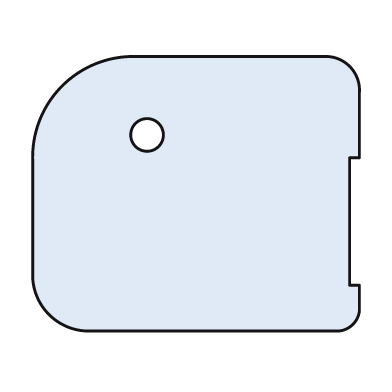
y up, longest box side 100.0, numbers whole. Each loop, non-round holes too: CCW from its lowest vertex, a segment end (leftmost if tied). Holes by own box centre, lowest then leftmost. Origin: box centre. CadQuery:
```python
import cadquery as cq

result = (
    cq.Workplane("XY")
    .moveTo(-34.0, -42.0)
    .lineTo(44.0, -42.0)
    .threePointArc((48.0, -40.0), (50.0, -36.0))
    .lineTo(50.0, -28.0)
    .lineTo(47.0, -28.0)
    .lineTo(47.0, 11.0)
    .lineTo(50.0, 11.0)
    .lineTo(50.0, 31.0)
    .threePointArc((47.0, 39.0), (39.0, 42.0))
    .lineTo(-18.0, 42.0)
    .threePointArc((-41.0, 33.0), (-50.0, 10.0))
    .lineTo(-50.0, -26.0)
    .threePointArc((-45.0, -37.0), (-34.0, -42.0))
    .close()
    .moveTo(-15.0, 18.0)
    .circle(5.0)
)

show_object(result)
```